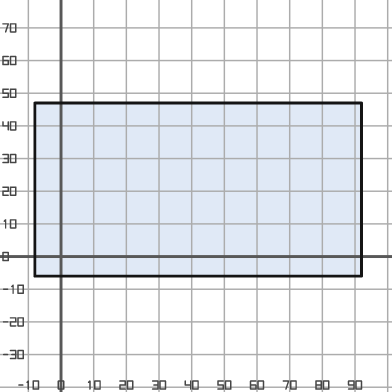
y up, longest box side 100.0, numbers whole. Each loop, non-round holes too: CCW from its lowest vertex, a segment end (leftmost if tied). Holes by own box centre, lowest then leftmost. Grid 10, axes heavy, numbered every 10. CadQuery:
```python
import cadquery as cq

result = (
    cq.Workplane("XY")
    .moveTo(-8.0, -6.0)
    .lineTo(92.0, -6.0)
    .lineTo(92.0, 47.0)
    .lineTo(-8.0, 47.0)
    .close()
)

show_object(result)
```